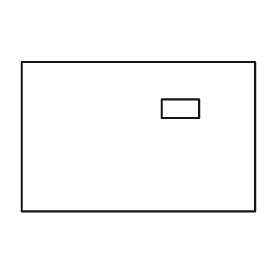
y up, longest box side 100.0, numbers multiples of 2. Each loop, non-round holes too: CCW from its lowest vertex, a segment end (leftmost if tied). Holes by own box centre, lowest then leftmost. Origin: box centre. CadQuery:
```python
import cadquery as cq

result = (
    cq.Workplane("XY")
    .moveTo(-50.0, -32.0)
    .lineTo(50.0, -32.0)
    .lineTo(50.0, 32.0)
    .lineTo(-50.0, 32.0)
    .close()
    .moveTo(10.0, 8.0)
    .lineTo(26.0, 8.0)
    .lineTo(26.0, 16.0)
    .lineTo(10.0, 16.0)
    .close()
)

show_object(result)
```